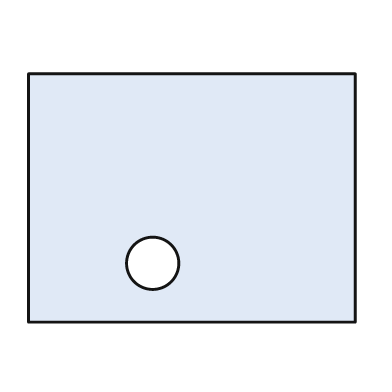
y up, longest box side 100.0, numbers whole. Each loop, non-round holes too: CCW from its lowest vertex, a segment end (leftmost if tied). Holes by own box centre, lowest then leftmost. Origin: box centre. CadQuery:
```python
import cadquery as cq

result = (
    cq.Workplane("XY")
    .moveTo(-50.0, -38.0)
    .lineTo(50.0, -38.0)
    .lineTo(50.0, 38.0)
    .lineTo(-50.0, 38.0)
    .close()
    .moveTo(-12.0, -20.0)
    .circle(8.0)
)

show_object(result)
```